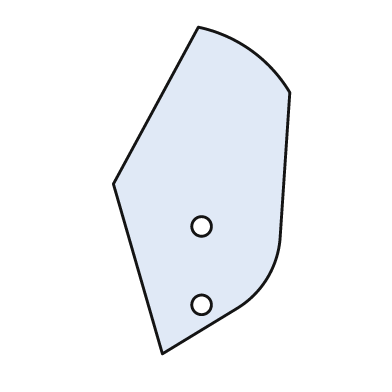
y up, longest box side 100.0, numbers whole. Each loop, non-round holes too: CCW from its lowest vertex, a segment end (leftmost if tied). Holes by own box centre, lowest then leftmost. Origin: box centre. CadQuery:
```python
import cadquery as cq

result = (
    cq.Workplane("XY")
    .moveTo(-12.0, -50.0)
    .lineTo(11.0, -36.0)
    .threePointArc((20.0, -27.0), (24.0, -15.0))
    .lineTo(27.0, 30.0)
    .threePointArc((15.0, 43.0), (-1.0, 50.0))
    .lineTo(-27.0, 2.0)
    .close()
    .moveTo(0.0, -35.0)
    .circle(3.0)
    .moveTo(0.0, -11.0)
    .circle(3.0)
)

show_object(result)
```